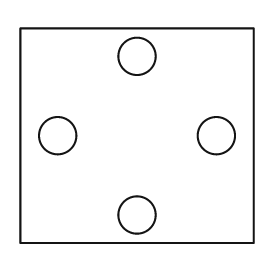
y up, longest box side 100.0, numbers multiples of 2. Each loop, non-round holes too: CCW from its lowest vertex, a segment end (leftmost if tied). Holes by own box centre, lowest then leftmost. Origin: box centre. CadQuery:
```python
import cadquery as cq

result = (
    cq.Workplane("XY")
    .moveTo(-50.0, -46.0)
    .lineTo(50.0, -46.0)
    .lineTo(50.0, 46.0)
    .lineTo(-50.0, 46.0)
    .close()
    .moveTo(0.0, -34.0)
    .circle(8.0)
    .moveTo(-34.0, 0.0)
    .circle(8.0)
    .moveTo(34.0, 0.0)
    .circle(8.0)
    .moveTo(0.0, 34.0)
    .circle(8.0)
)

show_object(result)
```